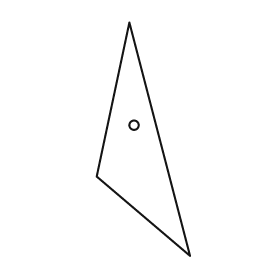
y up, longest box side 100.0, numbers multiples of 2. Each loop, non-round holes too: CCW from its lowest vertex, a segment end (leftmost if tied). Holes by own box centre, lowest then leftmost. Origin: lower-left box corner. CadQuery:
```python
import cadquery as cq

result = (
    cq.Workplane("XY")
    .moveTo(40.0, 0.0)
    .lineTo(14.0, 100.0)
    .lineTo(0.0, 34.0)
    .close()
    .moveTo(16.0, 56.0)
    .circle(2.0)
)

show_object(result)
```